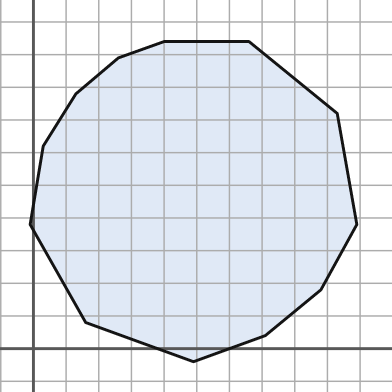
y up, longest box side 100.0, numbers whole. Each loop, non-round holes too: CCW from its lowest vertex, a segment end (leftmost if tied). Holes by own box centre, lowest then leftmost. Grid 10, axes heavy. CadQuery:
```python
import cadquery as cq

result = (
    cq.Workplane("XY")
    .moveTo(49.0, -4.0)
    .lineTo(71.0, 4.0)
    .lineTo(88.0, 18.0)
    .lineTo(99.0, 38.0)
    .lineTo(93.0, 72.0)
    .lineTo(66.0, 94.0)
    .lineTo(40.0, 94.0)
    .lineTo(26.0, 89.0)
    .lineTo(13.0, 78.0)
    .lineTo(3.0, 62.0)
    .lineTo(-1.0, 38.0)
    .lineTo(16.0, 8.0)
    .close()
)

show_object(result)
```